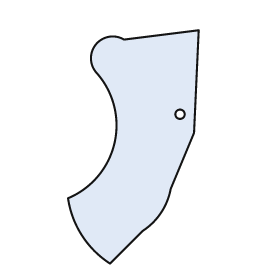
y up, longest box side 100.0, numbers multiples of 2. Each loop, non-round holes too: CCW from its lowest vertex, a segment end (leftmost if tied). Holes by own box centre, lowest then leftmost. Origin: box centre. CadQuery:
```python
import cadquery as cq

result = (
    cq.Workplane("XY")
    .moveTo(-10.0, -50.0)
    .lineTo(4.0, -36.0)
    .threePointArc((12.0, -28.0), (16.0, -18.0))
    .lineTo(26.0, 6.0)
    .lineTo(28.0, 50.0)
    .lineTo(-4.0, 46.0)
    .threePointArc((-16.0, 44.0), (-16.0, 32.0))
    .threePointArc((-8.0, 2.0), (-28.0, -22.0))
    .threePointArc((-22.0, -38.0), (-10.0, -50.0))
    .close()
    .moveTo(20.0, 14.0)
    .circle(2.0)
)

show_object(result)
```